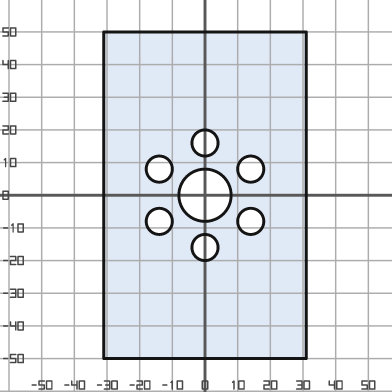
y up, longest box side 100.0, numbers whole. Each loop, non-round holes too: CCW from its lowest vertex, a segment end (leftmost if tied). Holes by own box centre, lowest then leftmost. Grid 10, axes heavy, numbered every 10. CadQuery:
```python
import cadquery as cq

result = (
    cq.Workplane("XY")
    .moveTo(-31.0, -50.0)
    .lineTo(31.0, -50.0)
    .lineTo(31.0, 50.0)
    .lineTo(-31.0, 50.0)
    .close()
    .moveTo(0.0, -16.0)
    .circle(4.0)
    .moveTo(-14.0, -8.0)
    .circle(4.0)
    .moveTo(14.0, -8.0)
    .circle(4.0)
    .moveTo(0.0, 0.0)
    .circle(8.0)
    .moveTo(-14.0, 8.0)
    .circle(4.0)
    .moveTo(14.0, 8.0)
    .circle(4.0)
    .moveTo(0.0, 16.0)
    .circle(4.0)
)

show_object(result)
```